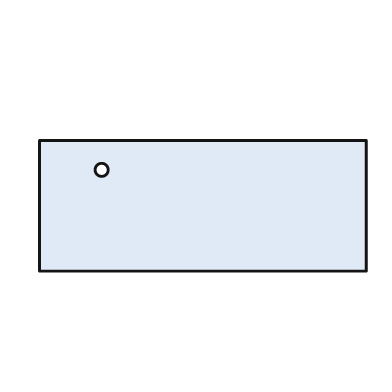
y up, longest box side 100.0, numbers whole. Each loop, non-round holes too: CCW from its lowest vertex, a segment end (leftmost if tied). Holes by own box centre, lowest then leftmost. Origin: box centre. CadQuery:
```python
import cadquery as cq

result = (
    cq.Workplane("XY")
    .moveTo(-50.0, -20.0)
    .lineTo(50.0, -20.0)
    .lineTo(50.0, 20.0)
    .lineTo(-50.0, 20.0)
    .close()
    .moveTo(-31.0, 11.0)
    .circle(2.0)
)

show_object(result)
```